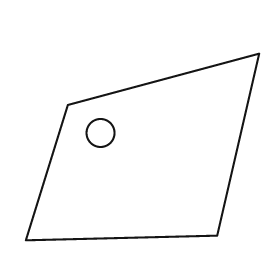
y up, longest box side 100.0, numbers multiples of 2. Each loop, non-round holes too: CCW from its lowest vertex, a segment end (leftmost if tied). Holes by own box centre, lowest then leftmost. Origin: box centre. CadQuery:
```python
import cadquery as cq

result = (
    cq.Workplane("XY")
    .moveTo(-50.0, -40.0)
    .lineTo(32.0, -38.0)
    .lineTo(50.0, 40.0)
    .lineTo(-32.0, 18.0)
    .close()
    .moveTo(-18.0, 6.0)
    .circle(6.0)
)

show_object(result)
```